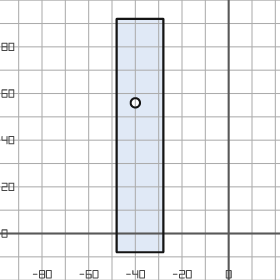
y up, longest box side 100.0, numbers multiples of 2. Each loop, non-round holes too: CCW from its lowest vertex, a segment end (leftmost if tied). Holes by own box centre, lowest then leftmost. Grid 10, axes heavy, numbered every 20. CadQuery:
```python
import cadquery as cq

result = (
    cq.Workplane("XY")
    .moveTo(-48.0, -8.0)
    .lineTo(-28.0, -8.0)
    .lineTo(-28.0, 92.0)
    .lineTo(-48.0, 92.0)
    .close()
    .moveTo(-40.0, 56.0)
    .circle(2.0)
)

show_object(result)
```